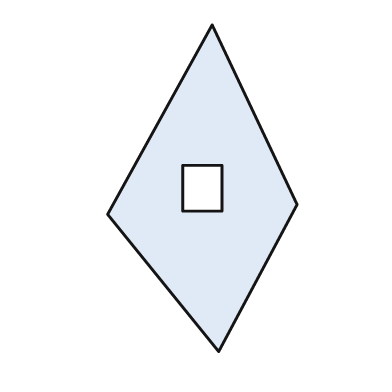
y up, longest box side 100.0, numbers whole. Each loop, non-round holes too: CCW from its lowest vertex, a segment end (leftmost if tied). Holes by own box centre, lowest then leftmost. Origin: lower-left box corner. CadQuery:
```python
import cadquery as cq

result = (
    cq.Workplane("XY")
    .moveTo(34.0, 0.0)
    .lineTo(58.0, 45.0)
    .lineTo(32.0, 100.0)
    .lineTo(0.0, 42.0)
    .close()
    .moveTo(23.0, 43.0)
    .lineTo(35.0, 43.0)
    .lineTo(35.0, 57.0)
    .lineTo(23.0, 57.0)
    .close()
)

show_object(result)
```